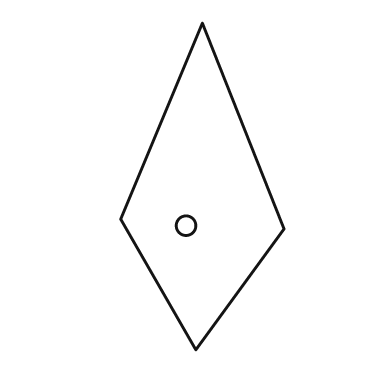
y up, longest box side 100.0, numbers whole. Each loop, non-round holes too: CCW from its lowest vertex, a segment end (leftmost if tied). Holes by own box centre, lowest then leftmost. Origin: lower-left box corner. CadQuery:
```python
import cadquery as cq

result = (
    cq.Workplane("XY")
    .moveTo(23.0, 0.0)
    .lineTo(50.0, 37.0)
    .lineTo(25.0, 100.0)
    .lineTo(0.0, 40.0)
    .close()
    .moveTo(20.0, 38.0)
    .circle(3.0)
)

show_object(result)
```